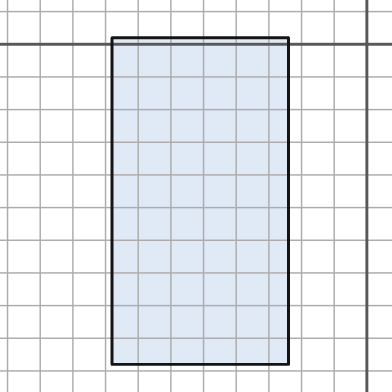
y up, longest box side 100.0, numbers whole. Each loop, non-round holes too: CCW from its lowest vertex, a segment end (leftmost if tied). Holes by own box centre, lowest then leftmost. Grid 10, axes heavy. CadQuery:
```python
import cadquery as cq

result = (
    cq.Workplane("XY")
    .moveTo(-78.0, -98.0)
    .lineTo(-24.0, -98.0)
    .lineTo(-24.0, 2.0)
    .lineTo(-78.0, 2.0)
    .close()
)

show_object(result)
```